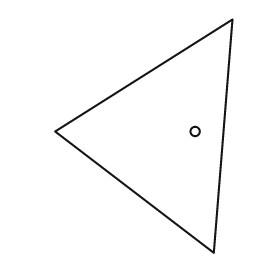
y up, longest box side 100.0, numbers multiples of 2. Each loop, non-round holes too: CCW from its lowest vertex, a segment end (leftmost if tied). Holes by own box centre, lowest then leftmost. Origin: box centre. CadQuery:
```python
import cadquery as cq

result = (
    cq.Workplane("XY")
    .moveTo(30.0, -50.0)
    .lineTo(38.0, 50.0)
    .lineTo(-38.0, 2.0)
    .close()
    .moveTo(22.0, 2.0)
    .circle(2.0)
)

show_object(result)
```